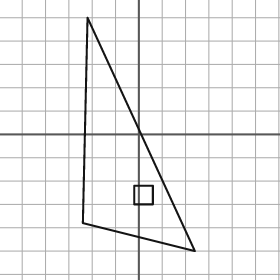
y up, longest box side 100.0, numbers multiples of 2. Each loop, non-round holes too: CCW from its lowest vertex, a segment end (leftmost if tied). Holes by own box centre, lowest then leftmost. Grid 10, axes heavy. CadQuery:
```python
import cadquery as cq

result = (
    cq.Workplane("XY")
    .moveTo(24.0, -50.0)
    .lineTo(-22.0, 50.0)
    .lineTo(-24.0, -38.0)
    .close()
    .moveTo(-2.0, -30.0)
    .lineTo(6.0, -30.0)
    .lineTo(6.0, -22.0)
    .lineTo(-2.0, -22.0)
    .close()
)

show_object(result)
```